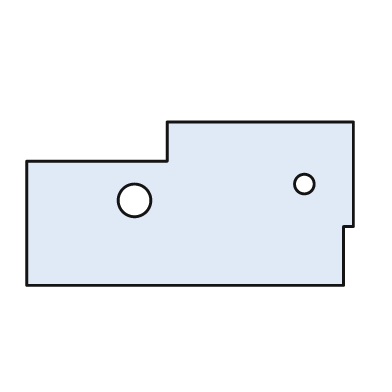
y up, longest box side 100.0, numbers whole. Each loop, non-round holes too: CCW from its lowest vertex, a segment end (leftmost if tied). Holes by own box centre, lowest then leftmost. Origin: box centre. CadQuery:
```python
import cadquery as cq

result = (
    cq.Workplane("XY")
    .moveTo(-50.0, -25.0)
    .lineTo(47.0, -25.0)
    .lineTo(47.0, -7.0)
    .lineTo(50.0, -7.0)
    .lineTo(50.0, 25.0)
    .lineTo(-7.0, 25.0)
    .lineTo(-7.0, 13.0)
    .lineTo(-50.0, 13.0)
    .close()
    .moveTo(-17.0, 1.0)
    .circle(5.0)
    .moveTo(35.0, 6.0)
    .circle(3.0)
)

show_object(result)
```